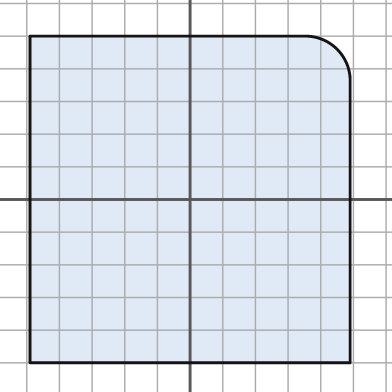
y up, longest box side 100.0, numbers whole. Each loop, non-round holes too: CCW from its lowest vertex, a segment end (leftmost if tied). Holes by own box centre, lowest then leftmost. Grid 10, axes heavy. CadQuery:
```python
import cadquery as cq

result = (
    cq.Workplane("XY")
    .moveTo(-49.0, -50.0)
    .lineTo(49.0, -50.0)
    .lineTo(49.0, 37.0)
    .threePointArc((45.0, 46.0), (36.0, 50.0))
    .lineTo(-49.0, 50.0)
    .close()
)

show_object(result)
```